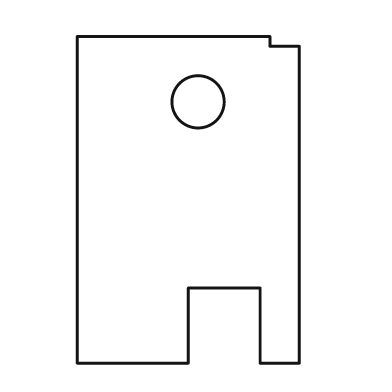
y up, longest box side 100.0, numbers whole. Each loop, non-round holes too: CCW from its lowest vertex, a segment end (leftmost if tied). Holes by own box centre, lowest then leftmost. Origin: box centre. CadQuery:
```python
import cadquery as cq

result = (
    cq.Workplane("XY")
    .moveTo(-34.0, -50.0)
    .lineTo(0.0, -50.0)
    .lineTo(0.0, -27.0)
    .lineTo(22.0, -27.0)
    .lineTo(22.0, -50.0)
    .lineTo(34.0, -50.0)
    .lineTo(34.0, 47.0)
    .lineTo(25.0, 47.0)
    .lineTo(25.0, 50.0)
    .lineTo(-34.0, 50.0)
    .close()
    .moveTo(3.0, 30.0)
    .circle(8.0)
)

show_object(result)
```